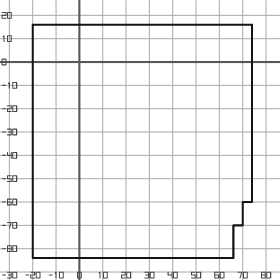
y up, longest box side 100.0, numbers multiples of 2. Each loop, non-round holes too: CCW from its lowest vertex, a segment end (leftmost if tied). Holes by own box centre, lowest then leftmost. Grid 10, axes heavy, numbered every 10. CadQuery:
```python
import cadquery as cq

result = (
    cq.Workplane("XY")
    .moveTo(-20.0, -84.0)
    .lineTo(66.0, -84.0)
    .lineTo(66.0, -70.0)
    .lineTo(70.0, -70.0)
    .lineTo(70.0, -60.0)
    .lineTo(74.0, -60.0)
    .lineTo(74.0, 16.0)
    .lineTo(-20.0, 16.0)
    .close()
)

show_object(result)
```